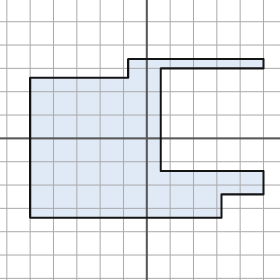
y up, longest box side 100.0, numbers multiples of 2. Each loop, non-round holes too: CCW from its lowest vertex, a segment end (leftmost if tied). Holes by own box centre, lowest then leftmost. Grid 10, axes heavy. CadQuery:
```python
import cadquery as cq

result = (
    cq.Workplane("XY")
    .moveTo(-50.0, -34.0)
    .lineTo(32.0, -34.0)
    .lineTo(32.0, -24.0)
    .lineTo(50.0, -24.0)
    .lineTo(50.0, -14.0)
    .lineTo(6.0, -14.0)
    .lineTo(6.0, 30.0)
    .lineTo(50.0, 30.0)
    .lineTo(50.0, 34.0)
    .lineTo(-8.0, 34.0)
    .lineTo(-8.0, 26.0)
    .lineTo(-50.0, 26.0)
    .close()
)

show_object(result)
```